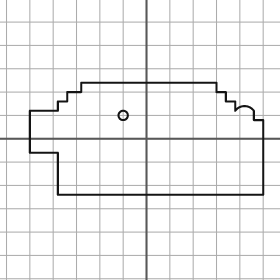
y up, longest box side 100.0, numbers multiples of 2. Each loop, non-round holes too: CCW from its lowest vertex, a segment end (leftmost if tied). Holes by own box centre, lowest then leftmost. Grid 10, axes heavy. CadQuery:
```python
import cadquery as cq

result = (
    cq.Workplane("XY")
    .moveTo(-38.0, -24.0)
    .lineTo(50.0, -24.0)
    .lineTo(50.0, 8.0)
    .lineTo(46.0, 8.0)
    .lineTo(46.0, 12.0)
    .threePointArc((42.0, 14.0), (38.0, 12.0))
    .lineTo(38.0, 16.0)
    .lineTo(34.0, 16.0)
    .lineTo(34.0, 20.0)
    .lineTo(30.0, 20.0)
    .lineTo(30.0, 24.0)
    .lineTo(-28.0, 24.0)
    .lineTo(-28.0, 20.0)
    .lineTo(-34.0, 20.0)
    .lineTo(-34.0, 16.0)
    .lineTo(-38.0, 16.0)
    .lineTo(-38.0, 12.0)
    .lineTo(-50.0, 12.0)
    .lineTo(-50.0, -6.0)
    .lineTo(-38.0, -6.0)
    .close()
    .moveTo(-10.0, 10.0)
    .circle(2.0)
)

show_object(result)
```